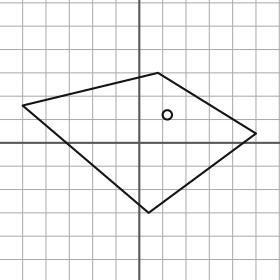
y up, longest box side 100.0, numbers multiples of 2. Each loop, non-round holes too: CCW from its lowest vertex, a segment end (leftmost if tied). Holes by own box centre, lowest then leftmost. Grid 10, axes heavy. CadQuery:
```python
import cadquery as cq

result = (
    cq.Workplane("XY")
    .moveTo(4.0, -30.0)
    .lineTo(50.0, 4.0)
    .lineTo(8.0, 30.0)
    .lineTo(-50.0, 16.0)
    .close()
    .moveTo(12.0, 12.0)
    .circle(2.0)
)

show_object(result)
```